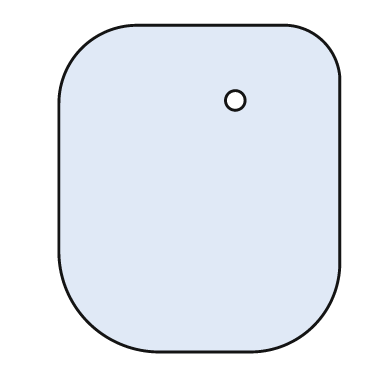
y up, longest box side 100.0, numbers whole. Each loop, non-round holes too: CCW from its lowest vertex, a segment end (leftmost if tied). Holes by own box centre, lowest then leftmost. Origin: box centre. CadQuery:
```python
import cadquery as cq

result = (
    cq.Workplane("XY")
    .moveTo(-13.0, -50.0)
    .lineTo(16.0, -50.0)
    .threePointArc((35.0, -42.0), (43.0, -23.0))
    .lineTo(43.0, 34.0)
    .threePointArc((38.0, 45.0), (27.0, 50.0))
    .lineTo(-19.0, 50.0)
    .threePointArc((-36.0, 43.0), (-43.0, 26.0))
    .lineTo(-43.0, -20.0)
    .threePointArc((-34.0, -41.0), (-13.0, -50.0))
    .close()
    .moveTo(11.0, 27.0)
    .circle(3.0)
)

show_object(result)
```